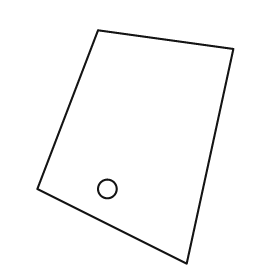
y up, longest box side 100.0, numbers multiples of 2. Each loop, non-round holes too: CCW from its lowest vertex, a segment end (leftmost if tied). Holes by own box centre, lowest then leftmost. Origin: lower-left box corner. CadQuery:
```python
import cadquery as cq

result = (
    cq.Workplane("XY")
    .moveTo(64.0, 0.0)
    .lineTo(84.0, 92.0)
    .lineTo(26.0, 100.0)
    .lineTo(0.0, 32.0)
    .close()
    .moveTo(30.0, 32.0)
    .circle(4.0)
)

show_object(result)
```